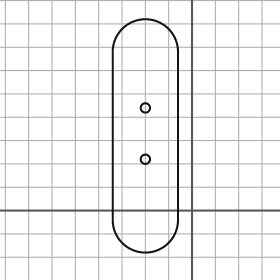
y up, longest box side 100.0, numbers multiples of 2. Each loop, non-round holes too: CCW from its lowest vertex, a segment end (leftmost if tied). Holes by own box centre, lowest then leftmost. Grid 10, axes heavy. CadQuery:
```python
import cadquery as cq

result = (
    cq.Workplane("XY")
    .moveTo(-34.0, -4.0)
    .threePointArc((-20.0, -18.0), (-6.0, -4.0))
    .lineTo(-6.0, 68.0)
    .threePointArc((-20.0, 82.0), (-34.0, 68.0))
    .close()
    .moveTo(-20.0, 22.0)
    .circle(2.0)
    .moveTo(-20.0, 44.0)
    .circle(2.0)
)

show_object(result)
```